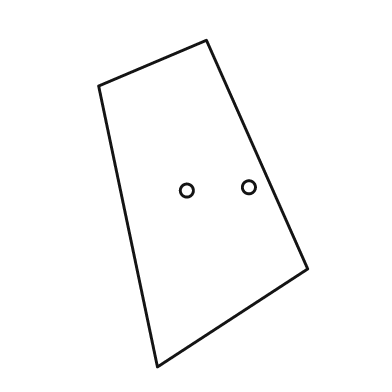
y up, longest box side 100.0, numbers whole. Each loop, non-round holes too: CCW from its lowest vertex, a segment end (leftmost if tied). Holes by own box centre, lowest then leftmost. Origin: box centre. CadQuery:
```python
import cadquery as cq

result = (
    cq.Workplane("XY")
    .moveTo(-14.0, -50.0)
    .lineTo(32.0, -20.0)
    .lineTo(1.0, 50.0)
    .lineTo(-32.0, 36.0)
    .close()
    .moveTo(-5.0, 4.0)
    .circle(2.0)
    .moveTo(14.0, 5.0)
    .circle(2.0)
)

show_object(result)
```